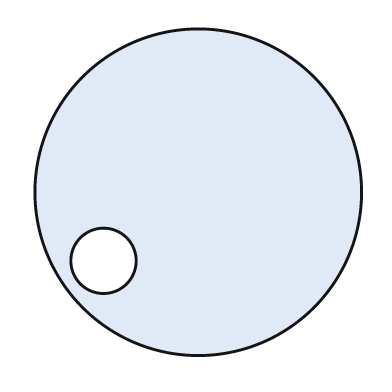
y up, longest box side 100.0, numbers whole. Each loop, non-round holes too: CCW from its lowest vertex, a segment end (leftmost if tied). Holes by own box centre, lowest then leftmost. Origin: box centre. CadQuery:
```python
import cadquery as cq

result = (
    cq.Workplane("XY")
    .moveTo(0.0, 0.0)
    .circle(50.0)
    .moveTo(-29.0, -21.0)
    .circle(10.0)
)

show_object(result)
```